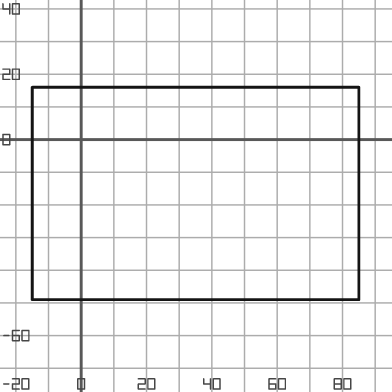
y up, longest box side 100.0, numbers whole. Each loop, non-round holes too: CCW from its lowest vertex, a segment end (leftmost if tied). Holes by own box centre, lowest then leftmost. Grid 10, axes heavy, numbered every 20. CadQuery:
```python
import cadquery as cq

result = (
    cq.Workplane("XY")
    .moveTo(-15.0, -49.0)
    .lineTo(85.0, -49.0)
    .lineTo(85.0, 16.0)
    .lineTo(-15.0, 16.0)
    .close()
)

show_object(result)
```